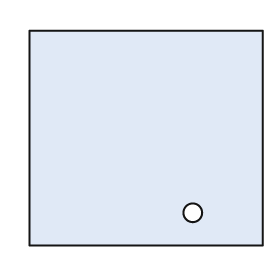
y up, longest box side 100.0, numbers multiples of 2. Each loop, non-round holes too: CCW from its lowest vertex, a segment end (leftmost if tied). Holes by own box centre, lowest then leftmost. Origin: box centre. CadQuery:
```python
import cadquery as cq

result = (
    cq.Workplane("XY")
    .moveTo(-50.0, -46.0)
    .lineTo(50.0, -46.0)
    .lineTo(50.0, 46.0)
    .lineTo(-50.0, 46.0)
    .close()
    .moveTo(20.0, -32.0)
    .circle(4.0)
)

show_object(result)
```